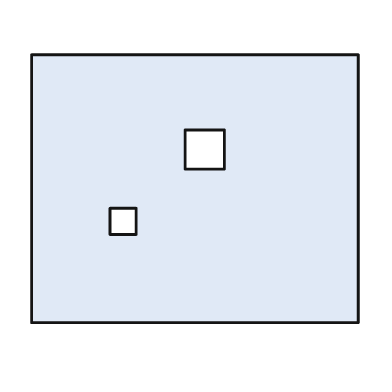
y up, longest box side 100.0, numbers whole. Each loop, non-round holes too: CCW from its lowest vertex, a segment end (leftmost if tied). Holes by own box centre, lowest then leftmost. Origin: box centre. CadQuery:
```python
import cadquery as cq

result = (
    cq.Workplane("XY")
    .moveTo(-50.0, -41.0)
    .lineTo(50.0, -41.0)
    .lineTo(50.0, 41.0)
    .lineTo(-50.0, 41.0)
    .close()
    .moveTo(-26.0, -14.0)
    .lineTo(-18.0, -14.0)
    .lineTo(-18.0, -6.0)
    .lineTo(-26.0, -6.0)
    .close()
    .moveTo(-3.0, 6.0)
    .lineTo(9.0, 6.0)
    .lineTo(9.0, 18.0)
    .lineTo(-3.0, 18.0)
    .close()
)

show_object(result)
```